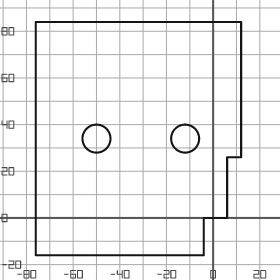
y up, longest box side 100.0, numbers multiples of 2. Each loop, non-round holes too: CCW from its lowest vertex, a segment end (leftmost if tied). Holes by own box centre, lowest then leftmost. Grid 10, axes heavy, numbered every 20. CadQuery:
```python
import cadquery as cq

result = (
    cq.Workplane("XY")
    .moveTo(-76.0, -16.0)
    .lineTo(-4.0, -16.0)
    .lineTo(-4.0, 0.0)
    .lineTo(6.0, 0.0)
    .lineTo(6.0, 26.0)
    .lineTo(12.0, 26.0)
    .lineTo(12.0, 84.0)
    .lineTo(-76.0, 84.0)
    .close()
    .moveTo(-50.0, 34.0)
    .circle(6.0)
    .moveTo(-12.0, 34.0)
    .circle(6.0)
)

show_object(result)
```